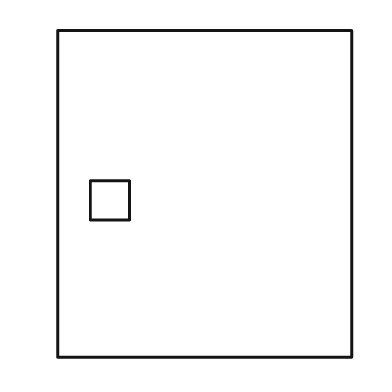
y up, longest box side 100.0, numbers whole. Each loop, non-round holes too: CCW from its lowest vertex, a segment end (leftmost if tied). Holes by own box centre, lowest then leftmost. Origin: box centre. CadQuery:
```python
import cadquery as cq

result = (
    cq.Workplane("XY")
    .moveTo(-45.0, -50.0)
    .lineTo(45.0, -50.0)
    .lineTo(45.0, 50.0)
    .lineTo(-45.0, 50.0)
    .close()
    .moveTo(-35.0, -8.0)
    .lineTo(-23.0, -8.0)
    .lineTo(-23.0, 4.0)
    .lineTo(-35.0, 4.0)
    .close()
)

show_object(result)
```